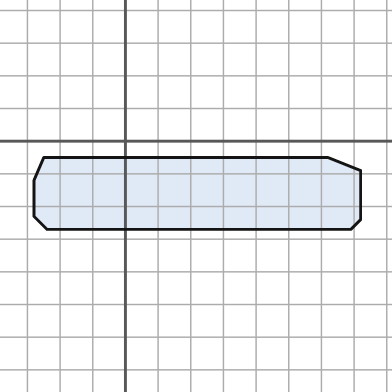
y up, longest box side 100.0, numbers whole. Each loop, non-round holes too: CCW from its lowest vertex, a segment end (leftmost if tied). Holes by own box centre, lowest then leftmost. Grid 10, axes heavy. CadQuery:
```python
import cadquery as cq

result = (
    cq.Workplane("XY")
    .moveTo(-24.0, -27.0)
    .lineTo(69.0, -27.0)
    .lineTo(72.0, -24.0)
    .lineTo(72.0, -9.0)
    .lineTo(62.0, -5.0)
    .lineTo(-25.0, -5.0)
    .lineTo(-28.0, -12.0)
    .lineTo(-28.0, -23.0)
    .close()
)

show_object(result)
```